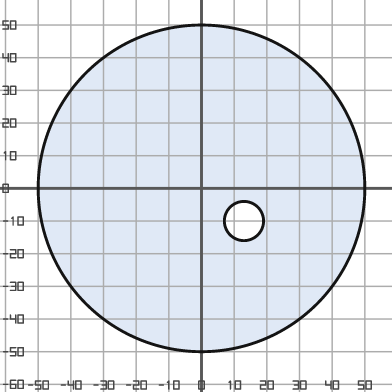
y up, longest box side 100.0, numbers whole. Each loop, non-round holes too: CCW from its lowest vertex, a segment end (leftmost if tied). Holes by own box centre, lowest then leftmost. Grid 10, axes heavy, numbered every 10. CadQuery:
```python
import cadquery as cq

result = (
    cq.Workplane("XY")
    .moveTo(0.0, 0.0)
    .circle(50.0)
    .moveTo(13.0, -10.0)
    .circle(6.0)
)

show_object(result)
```